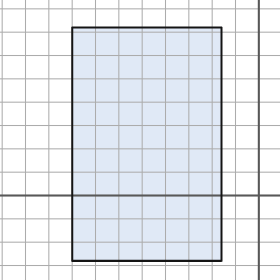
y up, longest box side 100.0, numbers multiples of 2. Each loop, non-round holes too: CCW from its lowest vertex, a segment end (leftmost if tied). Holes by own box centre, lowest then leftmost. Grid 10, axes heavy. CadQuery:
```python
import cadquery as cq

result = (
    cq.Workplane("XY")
    .moveTo(-80.0, -28.0)
    .lineTo(-16.0, -28.0)
    .lineTo(-16.0, 72.0)
    .lineTo(-80.0, 72.0)
    .close()
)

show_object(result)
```